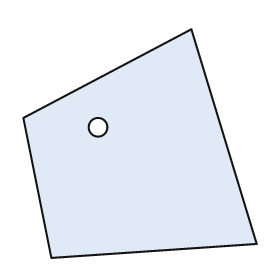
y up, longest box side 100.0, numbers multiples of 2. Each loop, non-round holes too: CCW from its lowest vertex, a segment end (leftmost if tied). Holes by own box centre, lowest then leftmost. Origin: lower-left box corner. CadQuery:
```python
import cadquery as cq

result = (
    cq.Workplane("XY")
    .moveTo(12.0, 0.0)
    .lineTo(100.0, 6.0)
    .lineTo(72.0, 98.0)
    .lineTo(0.0, 60.0)
    .close()
    .moveTo(32.0, 56.0)
    .circle(4.0)
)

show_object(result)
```